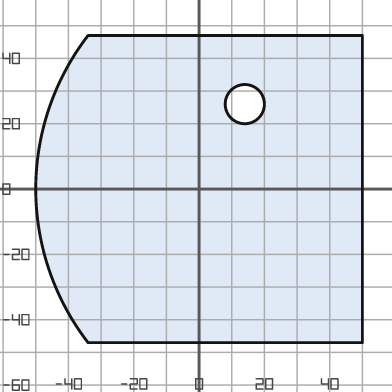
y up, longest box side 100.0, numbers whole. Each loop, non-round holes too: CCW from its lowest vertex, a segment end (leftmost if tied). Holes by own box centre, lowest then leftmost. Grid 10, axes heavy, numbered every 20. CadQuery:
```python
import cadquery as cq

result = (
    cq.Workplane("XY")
    .moveTo(-34.0, -47.0)
    .lineTo(50.0, -47.0)
    .lineTo(50.0, 47.0)
    .lineTo(-34.0, 47.0)
    .threePointArc((-50.0, 0.0), (-34.0, -47.0))
    .close()
    .moveTo(14.0, 26.0)
    .circle(6.0)
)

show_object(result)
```